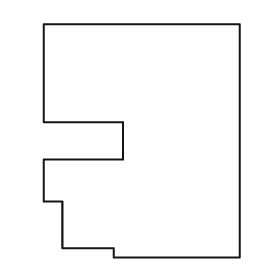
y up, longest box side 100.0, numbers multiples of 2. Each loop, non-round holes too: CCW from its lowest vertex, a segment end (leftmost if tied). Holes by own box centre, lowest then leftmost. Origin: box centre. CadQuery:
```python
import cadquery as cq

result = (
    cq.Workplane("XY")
    .moveTo(-12.0, -50.0)
    .lineTo(42.0, -50.0)
    .lineTo(42.0, 50.0)
    .lineTo(-42.0, 50.0)
    .lineTo(-42.0, 8.0)
    .lineTo(-8.0, 8.0)
    .lineTo(-8.0, -8.0)
    .lineTo(-42.0, -8.0)
    .lineTo(-42.0, -26.0)
    .lineTo(-34.0, -26.0)
    .lineTo(-34.0, -46.0)
    .lineTo(-12.0, -46.0)
    .close()
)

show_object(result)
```